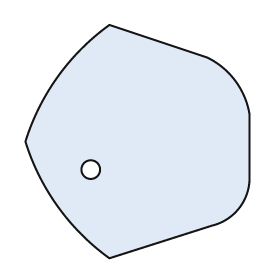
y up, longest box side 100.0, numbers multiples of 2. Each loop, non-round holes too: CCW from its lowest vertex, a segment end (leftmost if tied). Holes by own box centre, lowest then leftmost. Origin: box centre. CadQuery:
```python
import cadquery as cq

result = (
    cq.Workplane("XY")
    .moveTo(-12.0, -50.0)
    .lineTo(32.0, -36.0)
    .threePointArc((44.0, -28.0), (48.0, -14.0))
    .lineTo(48.0, 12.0)
    .threePointArc((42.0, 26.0), (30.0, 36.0))
    .lineTo(-12.0, 50.0)
    .threePointArc((-34.0, 28.0), (-48.0, 0.0))
    .threePointArc((-34.0, -28.0), (-12.0, -50.0))
    .close()
    .moveTo(-20.0, -12.0)
    .circle(4.0)
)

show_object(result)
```